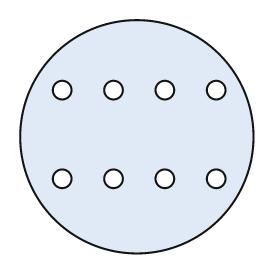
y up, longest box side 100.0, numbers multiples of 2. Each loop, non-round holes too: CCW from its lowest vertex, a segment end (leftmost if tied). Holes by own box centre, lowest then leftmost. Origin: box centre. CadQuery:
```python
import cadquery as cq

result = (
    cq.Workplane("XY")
    .moveTo(0.0, 0.0)
    .circle(50.0)
    .moveTo(-32.0, -18.0)
    .circle(4.0)
    .moveTo(-10.0, -18.0)
    .circle(4.0)
    .moveTo(12.0, -18.0)
    .circle(4.0)
    .moveTo(34.0, -18.0)
    .circle(4.0)
    .moveTo(-32.0, 20.0)
    .circle(4.0)
    .moveTo(-10.0, 20.0)
    .circle(4.0)
    .moveTo(12.0, 20.0)
    .circle(4.0)
    .moveTo(34.0, 20.0)
    .circle(4.0)
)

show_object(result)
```